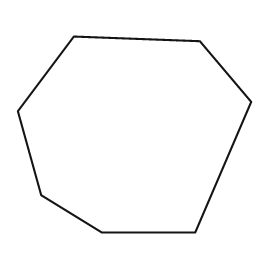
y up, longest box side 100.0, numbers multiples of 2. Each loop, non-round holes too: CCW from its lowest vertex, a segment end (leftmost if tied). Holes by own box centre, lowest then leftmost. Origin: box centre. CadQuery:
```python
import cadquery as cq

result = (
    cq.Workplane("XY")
    .moveTo(-14.0, -42.0)
    .lineTo(26.0, -42.0)
    .lineTo(50.0, 14.0)
    .lineTo(28.0, 40.0)
    .lineTo(-26.0, 42.0)
    .lineTo(-50.0, 10.0)
    .lineTo(-40.0, -26.0)
    .close()
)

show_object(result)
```